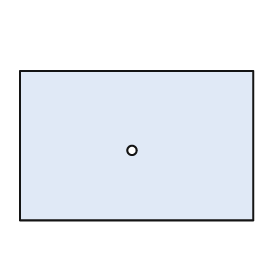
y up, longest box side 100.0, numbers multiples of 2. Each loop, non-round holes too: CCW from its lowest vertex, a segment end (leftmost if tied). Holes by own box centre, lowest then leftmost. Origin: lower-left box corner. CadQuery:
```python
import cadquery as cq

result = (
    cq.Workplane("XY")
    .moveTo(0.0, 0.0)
    .lineTo(100.0, 0.0)
    .lineTo(100.0, 64.0)
    .lineTo(0.0, 64.0)
    .close()
    .moveTo(48.0, 30.0)
    .circle(2.0)
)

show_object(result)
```